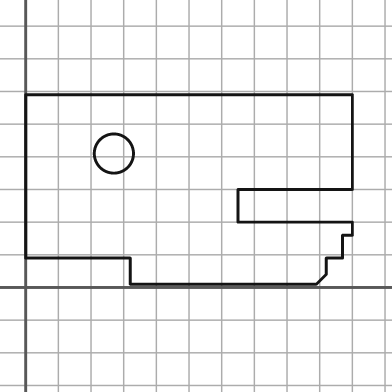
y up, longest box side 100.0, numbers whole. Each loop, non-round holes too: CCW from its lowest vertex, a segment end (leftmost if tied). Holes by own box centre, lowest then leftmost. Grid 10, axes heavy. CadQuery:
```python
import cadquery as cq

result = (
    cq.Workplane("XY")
    .moveTo(32.0, 1.0)
    .lineTo(89.0, 1.0)
    .lineTo(92.0, 4.0)
    .lineTo(92.0, 9.0)
    .lineTo(97.0, 9.0)
    .lineTo(97.0, 16.0)
    .lineTo(100.0, 16.0)
    .lineTo(100.0, 20.0)
    .lineTo(65.0, 20.0)
    .lineTo(65.0, 30.0)
    .lineTo(100.0, 30.0)
    .lineTo(100.0, 59.0)
    .lineTo(0.0, 59.0)
    .lineTo(0.0, 9.0)
    .lineTo(32.0, 9.0)
    .close()
    .moveTo(27.0, 41.0)
    .circle(6.0)
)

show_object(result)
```